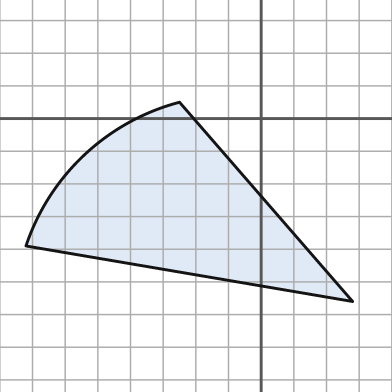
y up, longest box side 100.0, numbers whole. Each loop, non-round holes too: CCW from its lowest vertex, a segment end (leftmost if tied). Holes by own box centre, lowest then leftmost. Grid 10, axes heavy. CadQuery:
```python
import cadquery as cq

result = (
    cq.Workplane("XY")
    .moveTo(28.0, -56.0)
    .lineTo(-25.0, 5.0)
    .threePointArc((-54.0, -11.0), (-72.0, -39.0))
    .close()
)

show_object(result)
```